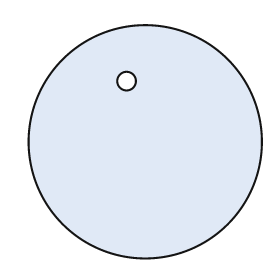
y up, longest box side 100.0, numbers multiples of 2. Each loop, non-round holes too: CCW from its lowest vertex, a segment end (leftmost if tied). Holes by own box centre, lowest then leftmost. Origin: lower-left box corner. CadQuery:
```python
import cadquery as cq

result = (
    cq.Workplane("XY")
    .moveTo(50.0, 50.0)
    .circle(50.0)
    .moveTo(42.0, 76.0)
    .circle(4.0)
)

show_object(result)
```